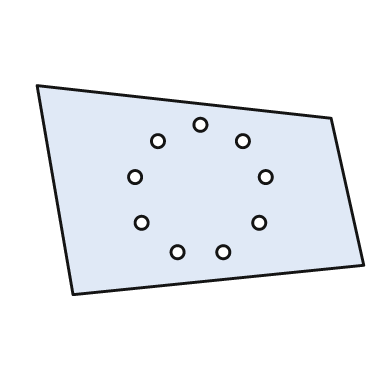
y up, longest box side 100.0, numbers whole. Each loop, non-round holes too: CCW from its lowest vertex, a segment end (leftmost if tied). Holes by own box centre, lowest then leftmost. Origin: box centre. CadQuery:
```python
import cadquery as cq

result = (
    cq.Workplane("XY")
    .moveTo(-39.0, -32.0)
    .lineTo(50.0, -23.0)
    .lineTo(40.0, 22.0)
    .lineTo(-50.0, 32.0)
    .close()
    .moveTo(-7.0, -19.0)
    .circle(2.0)
    .moveTo(7.0, -19.0)
    .circle(2.0)
    .moveTo(-18.0, -10.0)
    .circle(2.0)
    .moveTo(18.0, -10.0)
    .circle(2.0)
    .moveTo(-20.0, 4.0)
    .circle(2.0)
    .moveTo(20.0, 4.0)
    .circle(2.0)
    .moveTo(-13.0, 15.0)
    .circle(2.0)
    .moveTo(13.0, 15.0)
    .circle(2.0)
    .moveTo(0.0, 20.0)
    .circle(2.0)
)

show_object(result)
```